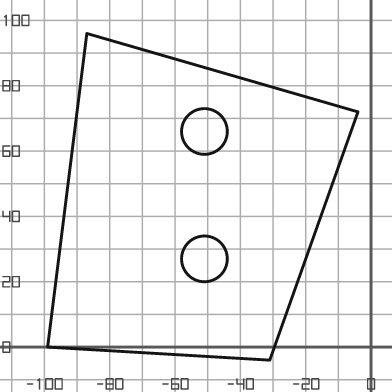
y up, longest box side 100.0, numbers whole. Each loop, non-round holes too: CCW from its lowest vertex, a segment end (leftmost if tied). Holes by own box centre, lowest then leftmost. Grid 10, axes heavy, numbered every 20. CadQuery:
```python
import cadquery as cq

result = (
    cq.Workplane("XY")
    .moveTo(-31.0, -4.0)
    .lineTo(-4.0, 72.0)
    .lineTo(-87.0, 96.0)
    .lineTo(-99.0, 0.0)
    .close()
    .moveTo(-51.0, 27.0)
    .circle(7.0)
    .moveTo(-51.0, 66.0)
    .circle(7.0)
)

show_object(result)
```